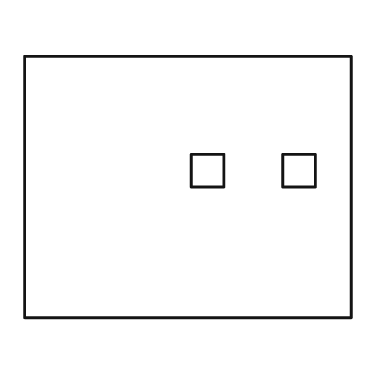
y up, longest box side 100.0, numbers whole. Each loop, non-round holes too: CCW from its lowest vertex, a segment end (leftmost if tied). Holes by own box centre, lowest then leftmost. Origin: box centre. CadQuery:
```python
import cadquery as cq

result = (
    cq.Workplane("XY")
    .moveTo(-50.0, -40.0)
    .lineTo(50.0, -40.0)
    .lineTo(50.0, 40.0)
    .lineTo(-50.0, 40.0)
    .close()
    .moveTo(1.0, 0.0)
    .lineTo(11.0, 0.0)
    .lineTo(11.0, 10.0)
    .lineTo(1.0, 10.0)
    .close()
    .moveTo(29.0, 0.0)
    .lineTo(39.0, 0.0)
    .lineTo(39.0, 10.0)
    .lineTo(29.0, 10.0)
    .close()
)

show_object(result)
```